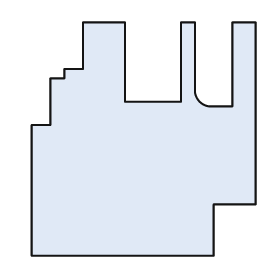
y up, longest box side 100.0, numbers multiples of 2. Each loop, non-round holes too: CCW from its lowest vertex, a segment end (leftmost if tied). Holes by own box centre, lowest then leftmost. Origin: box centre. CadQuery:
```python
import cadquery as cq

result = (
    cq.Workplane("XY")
    .moveTo(-48.0, -50.0)
    .lineTo(30.0, -50.0)
    .lineTo(30.0, -28.0)
    .lineTo(48.0, -28.0)
    .lineTo(48.0, 50.0)
    .lineTo(38.0, 50.0)
    .lineTo(38.0, 14.0)
    .lineTo(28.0, 14.0)
    .threePointArc((24.0, 16.0), (22.0, 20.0))
    .lineTo(22.0, 50.0)
    .lineTo(16.0, 50.0)
    .lineTo(16.0, 16.0)
    .lineTo(-8.0, 16.0)
    .lineTo(-8.0, 50.0)
    .lineTo(-26.0, 50.0)
    .lineTo(-26.0, 30.0)
    .lineTo(-34.0, 30.0)
    .lineTo(-34.0, 26.0)
    .lineTo(-40.0, 26.0)
    .lineTo(-40.0, 6.0)
    .lineTo(-48.0, 6.0)
    .close()
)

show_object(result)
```